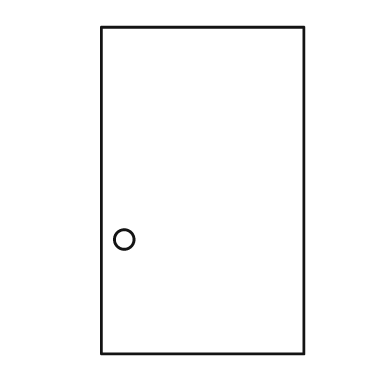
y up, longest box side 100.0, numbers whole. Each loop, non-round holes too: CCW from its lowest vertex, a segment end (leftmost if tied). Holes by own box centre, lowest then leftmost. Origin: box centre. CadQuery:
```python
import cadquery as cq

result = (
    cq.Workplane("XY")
    .moveTo(-31.0, -50.0)
    .lineTo(31.0, -50.0)
    .lineTo(31.0, 50.0)
    .lineTo(-31.0, 50.0)
    .close()
    .moveTo(-24.0, -15.0)
    .circle(3.0)
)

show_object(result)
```